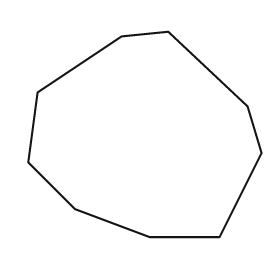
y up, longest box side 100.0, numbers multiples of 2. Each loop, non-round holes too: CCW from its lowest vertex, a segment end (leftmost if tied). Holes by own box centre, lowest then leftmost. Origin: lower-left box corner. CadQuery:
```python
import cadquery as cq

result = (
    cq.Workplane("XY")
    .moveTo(52.0, 0.0)
    .lineTo(82.0, 0.0)
    .lineTo(100.0, 36.0)
    .lineTo(94.0, 56.0)
    .lineTo(60.0, 88.0)
    .lineTo(40.0, 86.0)
    .lineTo(4.0, 62.0)
    .lineTo(0.0, 32.0)
    .lineTo(20.0, 12.0)
    .close()
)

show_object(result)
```